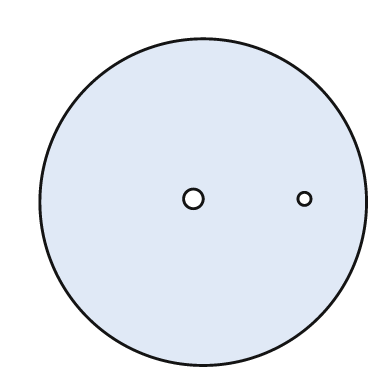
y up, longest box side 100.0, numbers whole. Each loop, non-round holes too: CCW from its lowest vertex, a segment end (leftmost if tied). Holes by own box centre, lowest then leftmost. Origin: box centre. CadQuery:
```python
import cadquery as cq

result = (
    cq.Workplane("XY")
    .moveTo(0.0, 0.0)
    .circle(50.0)
    .moveTo(-3.0, 1.0)
    .circle(3.0)
    .moveTo(31.0, 1.0)
    .circle(2.0)
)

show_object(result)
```